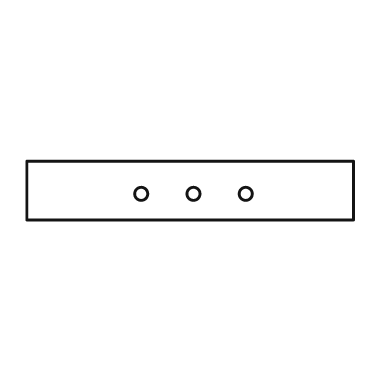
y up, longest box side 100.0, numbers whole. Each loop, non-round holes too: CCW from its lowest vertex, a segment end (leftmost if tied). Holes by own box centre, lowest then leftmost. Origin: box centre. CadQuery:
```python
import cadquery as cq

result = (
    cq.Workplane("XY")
    .moveTo(-50.0, -9.0)
    .lineTo(50.0, -9.0)
    .lineTo(50.0, 9.0)
    .lineTo(-50.0, 9.0)
    .close()
    .moveTo(-15.0, -1.0)
    .circle(2.0)
    .moveTo(1.0, -1.0)
    .circle(2.0)
    .moveTo(17.0, -1.0)
    .circle(2.0)
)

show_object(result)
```